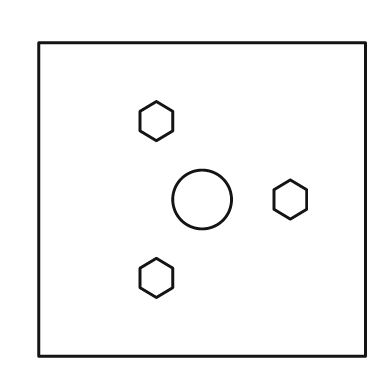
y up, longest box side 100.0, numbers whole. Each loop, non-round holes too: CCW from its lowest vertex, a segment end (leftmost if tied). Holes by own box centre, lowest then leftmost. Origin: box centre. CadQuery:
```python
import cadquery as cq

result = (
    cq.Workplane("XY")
    .moveTo(-50.0, -48.0)
    .lineTo(50.0, -48.0)
    .lineTo(50.0, 48.0)
    .lineTo(-50.0, 48.0)
    .close()
    .moveTo(-14.0, -30.0)
    .lineTo(-9.0, -27.0)
    .lineTo(-9.0, -21.0)
    .lineTo(-14.0, -18.0)
    .lineTo(-19.0, -21.0)
    .lineTo(-19.0, -27.0)
    .close()
    .moveTo(0.0, 0.0)
    .circle(9.0)
    .moveTo(27.0, -6.0)
    .lineTo(32.0, -3.0)
    .lineTo(32.0, 3.0)
    .lineTo(27.0, 6.0)
    .lineTo(22.0, 3.0)
    .lineTo(22.0, -3.0)
    .close()
    .moveTo(-14.0, 18.0)
    .lineTo(-9.0, 21.0)
    .lineTo(-9.0, 27.0)
    .lineTo(-14.0, 30.0)
    .lineTo(-19.0, 27.0)
    .lineTo(-19.0, 21.0)
    .close()
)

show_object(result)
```